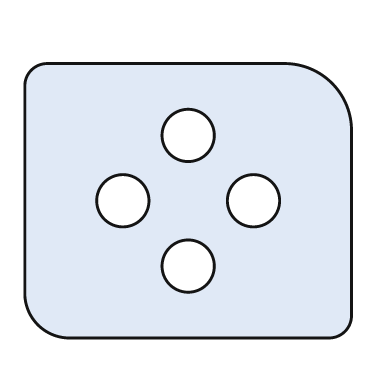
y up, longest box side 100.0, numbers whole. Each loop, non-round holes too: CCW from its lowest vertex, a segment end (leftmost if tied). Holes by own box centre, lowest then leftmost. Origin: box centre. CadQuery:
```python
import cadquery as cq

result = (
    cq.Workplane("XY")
    .moveTo(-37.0, -42.0)
    .lineTo(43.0, -42.0)
    .threePointArc((48.0, -40.0), (50.0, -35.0))
    .lineTo(50.0, 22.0)
    .threePointArc((44.0, 36.0), (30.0, 42.0))
    .lineTo(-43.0, 42.0)
    .threePointArc((-48.0, 40.0), (-50.0, 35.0))
    .lineTo(-50.0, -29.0)
    .threePointArc((-46.0, -38.0), (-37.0, -42.0))
    .close()
    .moveTo(0.0, -20.0)
    .circle(8.0)
    .moveTo(-20.0, 0.0)
    .circle(8.0)
    .moveTo(20.0, 0.0)
    .circle(8.0)
    .moveTo(0.0, 20.0)
    .circle(8.0)
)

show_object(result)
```